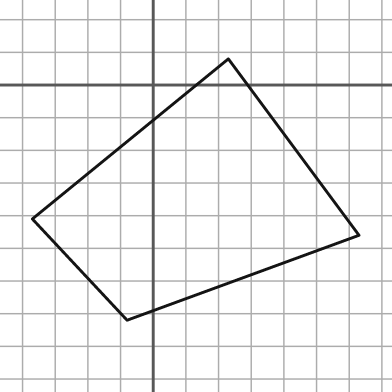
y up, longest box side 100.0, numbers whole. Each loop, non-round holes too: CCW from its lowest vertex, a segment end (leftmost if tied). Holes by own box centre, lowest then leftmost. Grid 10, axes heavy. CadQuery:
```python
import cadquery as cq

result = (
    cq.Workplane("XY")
    .moveTo(-8.0, -72.0)
    .lineTo(63.0, -46.0)
    .lineTo(23.0, 8.0)
    .lineTo(-37.0, -41.0)
    .close()
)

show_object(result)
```